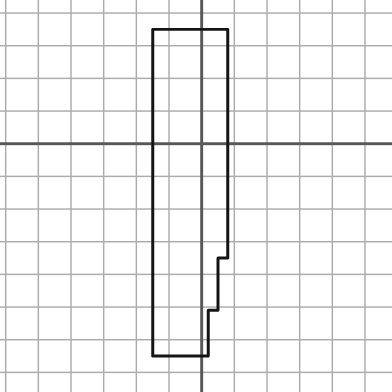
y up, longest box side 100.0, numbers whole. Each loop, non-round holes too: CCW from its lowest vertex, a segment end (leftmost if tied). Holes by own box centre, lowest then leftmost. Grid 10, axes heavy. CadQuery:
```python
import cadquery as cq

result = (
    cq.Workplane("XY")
    .moveTo(-15.0, -65.0)
    .lineTo(2.0, -65.0)
    .lineTo(2.0, -51.0)
    .lineTo(5.0, -51.0)
    .lineTo(5.0, -35.0)
    .lineTo(8.0, -35.0)
    .lineTo(8.0, 35.0)
    .lineTo(-15.0, 35.0)
    .close()
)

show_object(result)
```